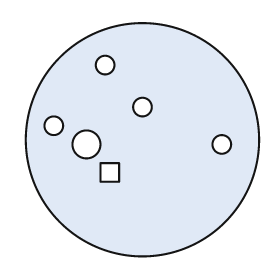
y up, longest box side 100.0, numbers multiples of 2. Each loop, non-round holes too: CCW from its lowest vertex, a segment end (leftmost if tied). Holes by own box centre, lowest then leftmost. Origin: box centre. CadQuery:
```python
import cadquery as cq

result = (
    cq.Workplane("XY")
    .moveTo(0.0, 0.0)
    .circle(50.0)
    .moveTo(-18.0, -18.0)
    .lineTo(-10.0, -18.0)
    .lineTo(-10.0, -10.0)
    .lineTo(-18.0, -10.0)
    .close()
    .moveTo(-24.0, -2.0)
    .circle(6.0)
    .moveTo(34.0, -2.0)
    .circle(4.0)
    .moveTo(-38.0, 6.0)
    .circle(4.0)
    .moveTo(0.0, 14.0)
    .circle(4.0)
    .moveTo(-16.0, 32.0)
    .circle(4.0)
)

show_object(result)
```